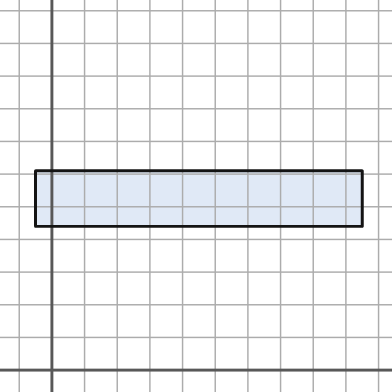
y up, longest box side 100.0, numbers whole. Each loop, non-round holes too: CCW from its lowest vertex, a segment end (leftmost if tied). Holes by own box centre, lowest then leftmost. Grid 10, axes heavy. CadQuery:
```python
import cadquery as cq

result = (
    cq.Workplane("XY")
    .moveTo(-5.0, 44.0)
    .lineTo(95.0, 44.0)
    .lineTo(95.0, 61.0)
    .lineTo(-5.0, 61.0)
    .close()
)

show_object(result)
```